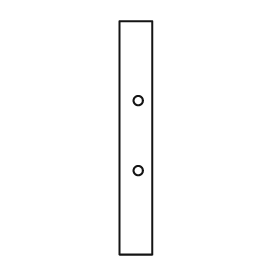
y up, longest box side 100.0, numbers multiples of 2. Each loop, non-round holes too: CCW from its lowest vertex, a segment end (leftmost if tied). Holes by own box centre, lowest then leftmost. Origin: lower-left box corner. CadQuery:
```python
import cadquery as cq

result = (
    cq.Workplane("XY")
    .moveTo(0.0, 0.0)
    .lineTo(14.0, 0.0)
    .lineTo(14.0, 100.0)
    .lineTo(0.0, 100.0)
    .close()
    .moveTo(8.0, 36.0)
    .circle(2.0)
    .moveTo(8.0, 66.0)
    .circle(2.0)
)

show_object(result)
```